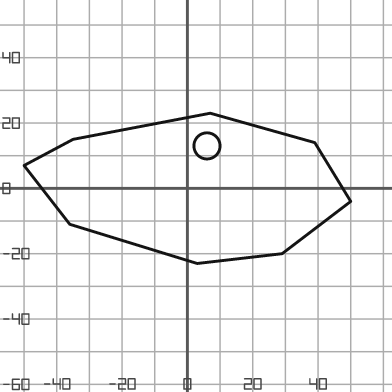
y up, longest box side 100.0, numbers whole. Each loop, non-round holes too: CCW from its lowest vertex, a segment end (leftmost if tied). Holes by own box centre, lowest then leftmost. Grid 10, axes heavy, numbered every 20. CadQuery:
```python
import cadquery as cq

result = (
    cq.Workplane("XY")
    .moveTo(3.0, -23.0)
    .lineTo(29.0, -20.0)
    .lineTo(50.0, -4.0)
    .lineTo(39.0, 14.0)
    .lineTo(7.0, 23.0)
    .lineTo(-35.0, 15.0)
    .lineTo(-50.0, 7.0)
    .lineTo(-36.0, -11.0)
    .close()
    .moveTo(6.0, 13.0)
    .circle(4.0)
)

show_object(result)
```